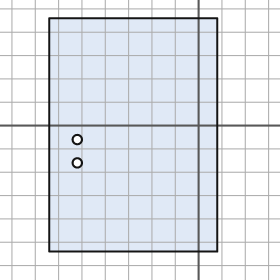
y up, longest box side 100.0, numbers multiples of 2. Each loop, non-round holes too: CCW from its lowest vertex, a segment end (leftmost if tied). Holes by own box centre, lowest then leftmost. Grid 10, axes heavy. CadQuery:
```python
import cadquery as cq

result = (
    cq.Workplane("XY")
    .moveTo(-64.0, -54.0)
    .lineTo(8.0, -54.0)
    .lineTo(8.0, 46.0)
    .lineTo(-64.0, 46.0)
    .close()
    .moveTo(-52.0, -16.0)
    .circle(2.0)
    .moveTo(-52.0, -6.0)
    .circle(2.0)
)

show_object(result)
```